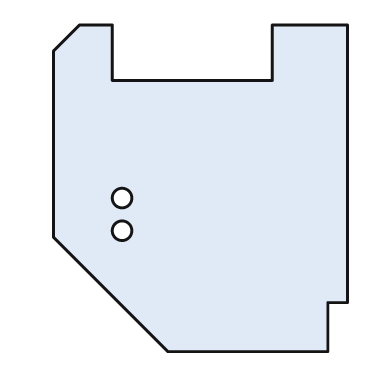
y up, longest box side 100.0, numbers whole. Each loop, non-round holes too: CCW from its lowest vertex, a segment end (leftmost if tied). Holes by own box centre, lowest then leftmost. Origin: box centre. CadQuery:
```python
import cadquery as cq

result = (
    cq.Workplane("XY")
    .moveTo(-10.0, -50.0)
    .lineTo(39.0, -50.0)
    .lineTo(39.0, -35.0)
    .lineTo(45.0, -35.0)
    .lineTo(45.0, 50.0)
    .lineTo(22.0, 50.0)
    .lineTo(22.0, 33.0)
    .lineTo(-27.0, 33.0)
    .lineTo(-27.0, 50.0)
    .lineTo(-37.0, 50.0)
    .lineTo(-45.0, 42.0)
    .lineTo(-45.0, -15.0)
    .close()
    .moveTo(-24.0, -13.0)
    .circle(3.0)
    .moveTo(-24.0, -3.0)
    .circle(3.0)
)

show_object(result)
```